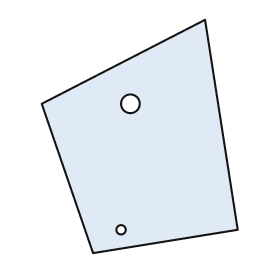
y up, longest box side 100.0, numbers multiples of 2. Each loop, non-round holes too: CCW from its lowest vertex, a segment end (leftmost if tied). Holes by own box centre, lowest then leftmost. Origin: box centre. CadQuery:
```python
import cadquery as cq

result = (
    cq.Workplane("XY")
    .moveTo(-20.0, -50.0)
    .lineTo(42.0, -40.0)
    .lineTo(28.0, 50.0)
    .lineTo(-42.0, 14.0)
    .close()
    .moveTo(-8.0, -40.0)
    .circle(2.0)
    .moveTo(-4.0, 14.0)
    .circle(4.0)
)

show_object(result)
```